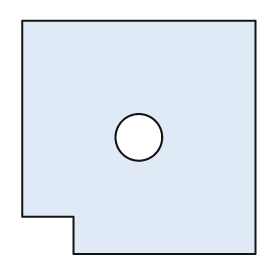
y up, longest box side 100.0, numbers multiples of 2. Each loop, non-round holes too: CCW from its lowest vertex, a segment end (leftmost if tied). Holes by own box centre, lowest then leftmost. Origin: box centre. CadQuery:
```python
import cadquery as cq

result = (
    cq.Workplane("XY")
    .moveTo(-28.0, -50.0)
    .lineTo(50.0, -50.0)
    .lineTo(50.0, 50.0)
    .lineTo(-50.0, 50.0)
    .lineTo(-50.0, -34.0)
    .lineTo(-28.0, -34.0)
    .close()
    .moveTo(0.0, 0.0)
    .circle(10.0)
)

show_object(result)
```